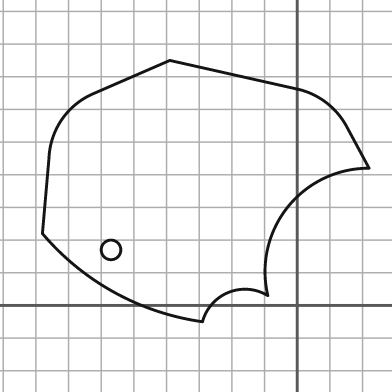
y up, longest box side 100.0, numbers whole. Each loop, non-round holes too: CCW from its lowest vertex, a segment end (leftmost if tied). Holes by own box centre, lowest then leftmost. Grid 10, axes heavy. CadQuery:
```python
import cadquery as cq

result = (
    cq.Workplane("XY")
    .moveTo(-29.0, -5.0)
    .threePointArc((-21.0, 4.0), (-9.0, 3.0))
    .threePointArc((-3.0, 30.0), (22.0, 42.0))
    .lineTo(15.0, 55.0)
    .threePointArc((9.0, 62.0), (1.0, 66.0))
    .lineTo(-39.0, 75.0)
    .lineTo(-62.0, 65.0)
    .threePointArc((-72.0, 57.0), (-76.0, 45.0))
    .lineTo(-78.0, 22.0)
    .threePointArc((-56.0, 4.0), (-29.0, -5.0))
    .close()
    .moveTo(-57.0, 17.0)
    .circle(3.0)
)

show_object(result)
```